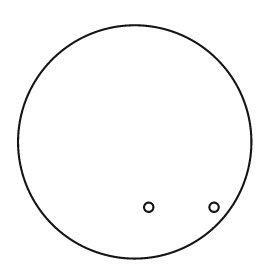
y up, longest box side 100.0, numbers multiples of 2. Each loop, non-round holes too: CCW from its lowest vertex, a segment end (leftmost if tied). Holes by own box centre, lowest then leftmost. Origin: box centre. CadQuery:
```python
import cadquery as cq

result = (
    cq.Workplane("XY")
    .moveTo(0.0, 0.0)
    .circle(50.0)
    .moveTo(6.0, -28.0)
    .circle(2.0)
    .moveTo(34.0, -28.0)
    .circle(2.0)
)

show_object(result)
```